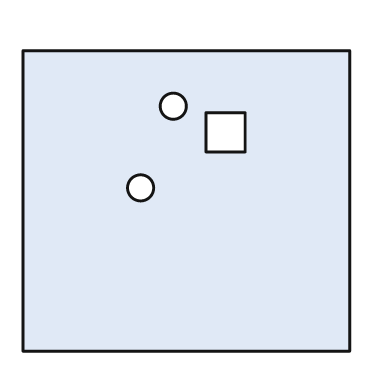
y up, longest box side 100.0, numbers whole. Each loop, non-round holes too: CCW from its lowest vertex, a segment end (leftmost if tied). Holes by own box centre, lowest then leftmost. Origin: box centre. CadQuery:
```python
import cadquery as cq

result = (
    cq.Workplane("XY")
    .moveTo(-50.0, -46.0)
    .lineTo(50.0, -46.0)
    .lineTo(50.0, 46.0)
    .lineTo(-50.0, 46.0)
    .close()
    .moveTo(-14.0, 4.0)
    .circle(4.0)
    .moveTo(6.0, 15.0)
    .lineTo(18.0, 15.0)
    .lineTo(18.0, 27.0)
    .lineTo(6.0, 27.0)
    .close()
    .moveTo(-4.0, 29.0)
    .circle(4.0)
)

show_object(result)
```